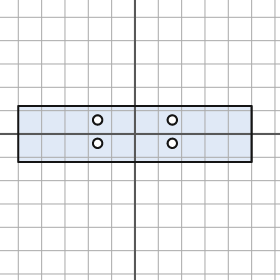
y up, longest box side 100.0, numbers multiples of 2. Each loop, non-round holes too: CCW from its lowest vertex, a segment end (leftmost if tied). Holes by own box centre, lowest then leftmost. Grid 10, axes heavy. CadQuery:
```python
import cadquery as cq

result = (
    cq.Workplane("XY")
    .moveTo(-50.0, -12.0)
    .lineTo(50.0, -12.0)
    .lineTo(50.0, 12.0)
    .lineTo(-50.0, 12.0)
    .close()
    .moveTo(-16.0, -4.0)
    .circle(2.0)
    .moveTo(16.0, -4.0)
    .circle(2.0)
    .moveTo(-16.0, 6.0)
    .circle(2.0)
    .moveTo(16.0, 6.0)
    .circle(2.0)
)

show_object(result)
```